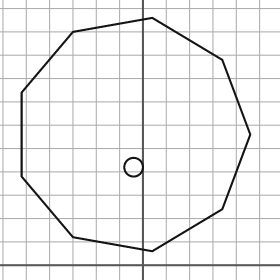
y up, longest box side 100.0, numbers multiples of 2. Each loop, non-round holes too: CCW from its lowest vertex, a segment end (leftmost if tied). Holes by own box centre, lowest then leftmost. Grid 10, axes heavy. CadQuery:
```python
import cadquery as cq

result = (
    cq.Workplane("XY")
    .moveTo(4.0, 6.0)
    .lineTo(34.0, 24.0)
    .lineTo(46.0, 56.0)
    .lineTo(34.0, 88.0)
    .lineTo(4.0, 106.0)
    .lineTo(-30.0, 100.0)
    .lineTo(-52.0, 74.0)
    .lineTo(-52.0, 38.0)
    .lineTo(-30.0, 12.0)
    .close()
    .moveTo(-4.0, 42.0)
    .circle(4.0)
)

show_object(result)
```